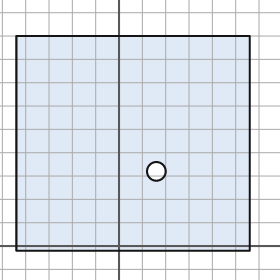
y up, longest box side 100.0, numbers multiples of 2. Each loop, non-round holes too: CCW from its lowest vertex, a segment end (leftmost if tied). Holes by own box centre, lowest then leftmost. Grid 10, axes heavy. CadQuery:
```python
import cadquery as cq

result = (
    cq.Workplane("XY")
    .moveTo(-44.0, -2.0)
    .lineTo(56.0, -2.0)
    .lineTo(56.0, 90.0)
    .lineTo(-44.0, 90.0)
    .close()
    .moveTo(16.0, 32.0)
    .circle(4.0)
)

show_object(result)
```